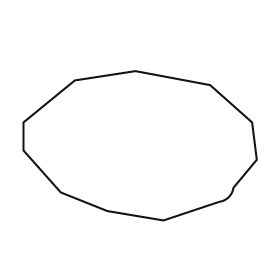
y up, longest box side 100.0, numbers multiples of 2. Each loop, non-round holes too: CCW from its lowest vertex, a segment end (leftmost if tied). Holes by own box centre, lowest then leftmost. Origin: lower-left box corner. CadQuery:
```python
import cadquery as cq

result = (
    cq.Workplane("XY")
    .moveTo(60.0, 0.0)
    .lineTo(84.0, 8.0)
    .threePointArc((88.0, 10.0), (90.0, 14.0))
    .lineTo(100.0, 26.0)
    .lineTo(98.0, 42.0)
    .lineTo(80.0, 58.0)
    .lineTo(48.0, 64.0)
    .lineTo(22.0, 60.0)
    .lineTo(0.0, 42.0)
    .lineTo(0.0, 30.0)
    .lineTo(16.0, 12.0)
    .lineTo(36.0, 4.0)
    .close()
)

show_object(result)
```